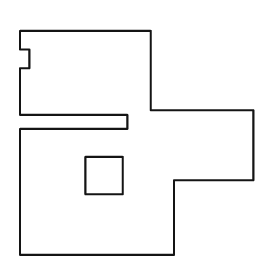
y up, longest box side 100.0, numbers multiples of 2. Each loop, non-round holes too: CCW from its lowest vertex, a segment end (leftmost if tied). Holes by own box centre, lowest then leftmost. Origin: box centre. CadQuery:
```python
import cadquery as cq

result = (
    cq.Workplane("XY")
    .moveTo(-50.0, -48.0)
    .lineTo(16.0, -48.0)
    .lineTo(16.0, -16.0)
    .lineTo(50.0, -16.0)
    .lineTo(50.0, 14.0)
    .lineTo(6.0, 14.0)
    .lineTo(6.0, 48.0)
    .lineTo(-50.0, 48.0)
    .lineTo(-50.0, 40.0)
    .lineTo(-46.0, 40.0)
    .lineTo(-46.0, 32.0)
    .lineTo(-50.0, 32.0)
    .lineTo(-50.0, 12.0)
    .lineTo(-4.0, 12.0)
    .lineTo(-4.0, 6.0)
    .lineTo(-50.0, 6.0)
    .close()
    .moveTo(-22.0, -22.0)
    .lineTo(-6.0, -22.0)
    .lineTo(-6.0, -6.0)
    .lineTo(-22.0, -6.0)
    .close()
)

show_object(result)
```